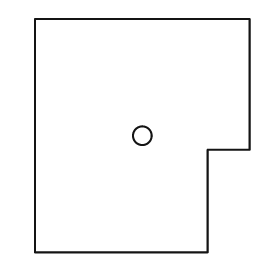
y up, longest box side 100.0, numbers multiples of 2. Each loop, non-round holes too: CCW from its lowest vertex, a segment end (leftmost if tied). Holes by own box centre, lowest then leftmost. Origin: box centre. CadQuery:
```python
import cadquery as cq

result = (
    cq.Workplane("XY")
    .moveTo(-46.0, -50.0)
    .lineTo(28.0, -50.0)
    .lineTo(28.0, -6.0)
    .lineTo(46.0, -6.0)
    .lineTo(46.0, 50.0)
    .lineTo(-46.0, 50.0)
    .close()
    .moveTo(0.0, 0.0)
    .circle(4.0)
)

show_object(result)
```